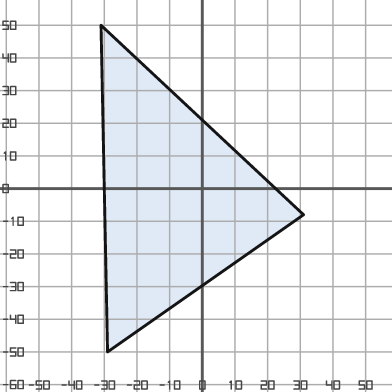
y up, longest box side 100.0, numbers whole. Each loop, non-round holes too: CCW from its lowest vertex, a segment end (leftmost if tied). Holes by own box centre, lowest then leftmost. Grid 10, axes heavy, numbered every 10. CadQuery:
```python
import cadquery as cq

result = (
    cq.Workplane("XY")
    .moveTo(-29.0, -50.0)
    .lineTo(31.0, -8.0)
    .lineTo(-31.0, 50.0)
    .close()
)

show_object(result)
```